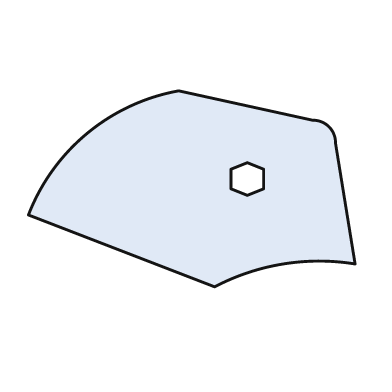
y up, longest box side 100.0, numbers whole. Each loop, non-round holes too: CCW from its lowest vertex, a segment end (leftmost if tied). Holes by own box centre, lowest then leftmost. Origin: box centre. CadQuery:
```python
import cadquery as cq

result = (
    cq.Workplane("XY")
    .moveTo(7.0, -30.0)
    .threePointArc((28.0, -23.0), (50.0, -23.0))
    .lineTo(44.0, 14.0)
    .threePointArc((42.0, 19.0), (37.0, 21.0))
    .lineTo(-4.0, 30.0)
    .threePointArc((-32.0, 17.0), (-50.0, -8.0))
    .close()
    .moveTo(17.0, -2.0)
    .lineTo(22.0, 0.0)
    .lineTo(22.0, 6.0)
    .lineTo(17.0, 8.0)
    .lineTo(12.0, 6.0)
    .lineTo(12.0, 0.0)
    .close()
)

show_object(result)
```